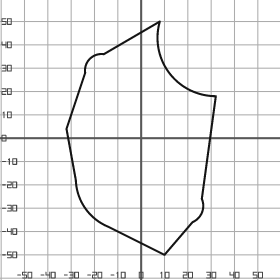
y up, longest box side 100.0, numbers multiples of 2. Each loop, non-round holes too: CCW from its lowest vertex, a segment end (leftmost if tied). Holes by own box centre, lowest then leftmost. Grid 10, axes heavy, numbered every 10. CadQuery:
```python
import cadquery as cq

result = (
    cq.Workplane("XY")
    .moveTo(10.0, -50.0)
    .lineTo(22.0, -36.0)
    .threePointArc((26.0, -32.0), (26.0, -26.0))
    .lineTo(32.0, 18.0)
    .threePointArc((12.0, 28.0), (8.0, 50.0))
    .lineTo(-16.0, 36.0)
    .threePointArc((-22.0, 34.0), (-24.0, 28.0))
    .lineTo(-32.0, 4.0)
    .lineTo(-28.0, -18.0)
    .threePointArc((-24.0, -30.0), (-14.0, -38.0))
    .close()
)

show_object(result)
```